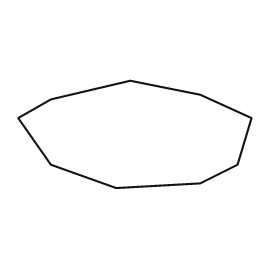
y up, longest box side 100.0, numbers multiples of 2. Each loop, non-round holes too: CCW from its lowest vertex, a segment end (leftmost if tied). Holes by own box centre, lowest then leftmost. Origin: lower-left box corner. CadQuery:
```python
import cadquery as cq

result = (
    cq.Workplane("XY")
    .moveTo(42.0, 0.0)
    .lineTo(78.0, 2.0)
    .lineTo(94.0, 10.0)
    .lineTo(100.0, 30.0)
    .lineTo(78.0, 40.0)
    .lineTo(48.0, 46.0)
    .lineTo(14.0, 38.0)
    .lineTo(0.0, 30.0)
    .lineTo(14.0, 10.0)
    .close()
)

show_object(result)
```